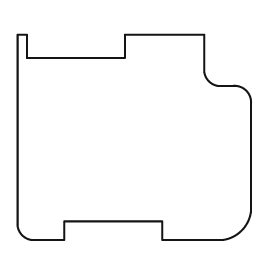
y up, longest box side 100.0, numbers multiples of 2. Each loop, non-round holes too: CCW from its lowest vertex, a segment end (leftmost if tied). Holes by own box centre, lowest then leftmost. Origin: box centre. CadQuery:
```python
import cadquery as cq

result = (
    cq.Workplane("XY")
    .moveTo(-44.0, -44.0)
    .lineTo(-30.0, -44.0)
    .lineTo(-30.0, -36.0)
    .lineTo(12.0, -36.0)
    .lineTo(12.0, -44.0)
    .lineTo(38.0, -44.0)
    .threePointArc((46.0, -40.0), (50.0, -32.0))
    .lineTo(50.0, 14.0)
    .threePointArc((48.0, 20.0), (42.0, 22.0))
    .lineTo(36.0, 22.0)
    .threePointArc((32.0, 24.0), (30.0, 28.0))
    .lineTo(30.0, 44.0)
    .lineTo(-4.0, 44.0)
    .lineTo(-4.0, 34.0)
    .lineTo(-46.0, 34.0)
    .lineTo(-46.0, 44.0)
    .lineTo(-50.0, 44.0)
    .lineTo(-50.0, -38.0)
    .threePointArc((-48.0, -42.0), (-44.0, -44.0))
    .close()
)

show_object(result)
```